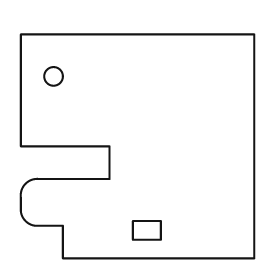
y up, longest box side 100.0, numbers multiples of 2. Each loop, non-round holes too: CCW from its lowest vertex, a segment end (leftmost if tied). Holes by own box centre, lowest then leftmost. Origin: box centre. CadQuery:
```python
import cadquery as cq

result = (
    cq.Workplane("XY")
    .moveTo(-32.0, -48.0)
    .lineTo(50.0, -48.0)
    .lineTo(50.0, 48.0)
    .lineTo(-50.0, 48.0)
    .lineTo(-50.0, 0.0)
    .lineTo(-12.0, 0.0)
    .lineTo(-12.0, -14.0)
    .lineTo(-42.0, -14.0)
    .threePointArc((-48.0, -16.0), (-50.0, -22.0))
    .lineTo(-50.0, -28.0)
    .threePointArc((-48.0, -32.0), (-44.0, -34.0))
    .lineTo(-32.0, -34.0)
    .close()
    .moveTo(-2.0, -40.0)
    .lineTo(10.0, -40.0)
    .lineTo(10.0, -32.0)
    .lineTo(-2.0, -32.0)
    .close()
    .moveTo(-36.0, 30.0)
    .circle(4.0)
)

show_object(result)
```